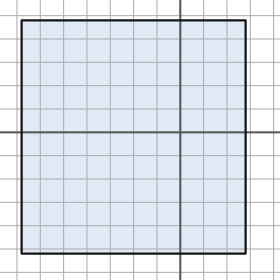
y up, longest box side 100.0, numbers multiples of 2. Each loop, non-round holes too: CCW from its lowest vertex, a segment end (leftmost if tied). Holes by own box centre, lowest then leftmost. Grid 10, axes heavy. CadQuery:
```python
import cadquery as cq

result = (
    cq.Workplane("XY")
    .moveTo(-68.0, -52.0)
    .lineTo(28.0, -52.0)
    .lineTo(28.0, 48.0)
    .lineTo(-68.0, 48.0)
    .close()
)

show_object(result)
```